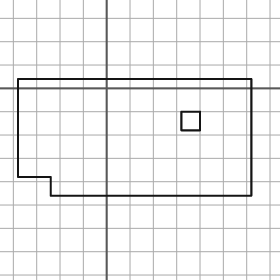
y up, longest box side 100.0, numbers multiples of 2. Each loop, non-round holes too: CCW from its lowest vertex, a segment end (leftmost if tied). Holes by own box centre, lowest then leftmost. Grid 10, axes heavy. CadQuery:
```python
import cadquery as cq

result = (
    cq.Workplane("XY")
    .moveTo(-24.0, -46.0)
    .lineTo(62.0, -46.0)
    .lineTo(62.0, 4.0)
    .lineTo(-38.0, 4.0)
    .lineTo(-38.0, -38.0)
    .lineTo(-24.0, -38.0)
    .close()
    .moveTo(32.0, -18.0)
    .lineTo(40.0, -18.0)
    .lineTo(40.0, -10.0)
    .lineTo(32.0, -10.0)
    .close()
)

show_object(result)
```